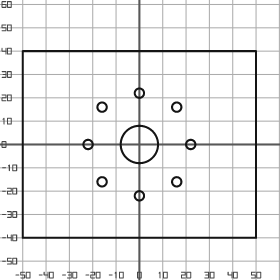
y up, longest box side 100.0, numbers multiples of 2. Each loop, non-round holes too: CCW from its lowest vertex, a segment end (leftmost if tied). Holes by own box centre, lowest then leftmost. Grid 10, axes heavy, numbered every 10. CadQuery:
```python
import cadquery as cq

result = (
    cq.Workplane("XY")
    .moveTo(-50.0, -40.0)
    .lineTo(50.0, -40.0)
    .lineTo(50.0, 40.0)
    .lineTo(-50.0, 40.0)
    .close()
    .moveTo(0.0, -22.0)
    .circle(2.0)
    .moveTo(-16.0, -16.0)
    .circle(2.0)
    .moveTo(16.0, -16.0)
    .circle(2.0)
    .moveTo(-22.0, 0.0)
    .circle(2.0)
    .moveTo(0.0, 0.0)
    .circle(8.0)
    .moveTo(22.0, 0.0)
    .circle(2.0)
    .moveTo(-16.0, 16.0)
    .circle(2.0)
    .moveTo(16.0, 16.0)
    .circle(2.0)
    .moveTo(0.0, 22.0)
    .circle(2.0)
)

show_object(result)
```